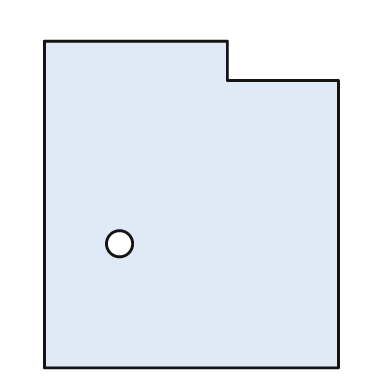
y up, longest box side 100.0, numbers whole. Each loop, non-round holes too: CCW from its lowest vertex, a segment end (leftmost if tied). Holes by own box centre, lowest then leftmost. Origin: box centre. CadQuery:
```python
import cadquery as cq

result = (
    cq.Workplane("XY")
    .moveTo(-45.0, -50.0)
    .lineTo(45.0, -50.0)
    .lineTo(45.0, 38.0)
    .lineTo(11.0, 38.0)
    .lineTo(11.0, 50.0)
    .lineTo(-45.0, 50.0)
    .close()
    .moveTo(-22.0, -12.0)
    .circle(4.0)
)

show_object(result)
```